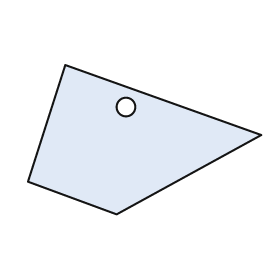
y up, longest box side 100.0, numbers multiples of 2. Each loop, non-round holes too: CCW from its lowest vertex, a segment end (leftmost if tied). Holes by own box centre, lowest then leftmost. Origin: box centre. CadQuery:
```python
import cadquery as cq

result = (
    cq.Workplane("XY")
    .moveTo(-12.0, -32.0)
    .lineTo(50.0, 2.0)
    .lineTo(-34.0, 32.0)
    .lineTo(-50.0, -18.0)
    .close()
    .moveTo(-8.0, 14.0)
    .circle(4.0)
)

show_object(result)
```